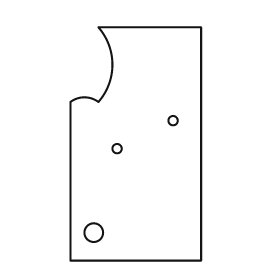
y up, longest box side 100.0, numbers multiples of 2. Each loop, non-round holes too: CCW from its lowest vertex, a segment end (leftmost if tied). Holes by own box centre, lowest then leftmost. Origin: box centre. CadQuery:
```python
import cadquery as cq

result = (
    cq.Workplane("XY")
    .moveTo(-28.0, -50.0)
    .lineTo(28.0, -50.0)
    .lineTo(28.0, 50.0)
    .lineTo(-16.0, 50.0)
    .threePointArc((-10.0, 34.0), (-16.0, 18.0))
    .threePointArc((-22.0, 20.0), (-28.0, 18.0))
    .close()
    .moveTo(-18.0, -38.0)
    .circle(4.0)
    .moveTo(-8.0, -2.0)
    .circle(2.0)
    .moveTo(16.0, 10.0)
    .circle(2.0)
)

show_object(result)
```